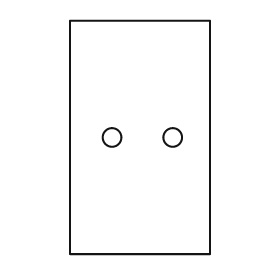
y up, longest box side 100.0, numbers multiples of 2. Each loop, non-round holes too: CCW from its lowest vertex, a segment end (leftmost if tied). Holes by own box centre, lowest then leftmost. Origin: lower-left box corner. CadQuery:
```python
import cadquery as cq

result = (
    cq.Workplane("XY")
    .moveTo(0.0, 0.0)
    .lineTo(60.0, 0.0)
    .lineTo(60.0, 100.0)
    .lineTo(0.0, 100.0)
    .close()
    .moveTo(18.0, 50.0)
    .circle(4.0)
    .moveTo(44.0, 50.0)
    .circle(4.0)
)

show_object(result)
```